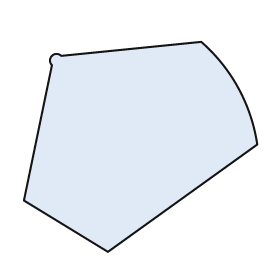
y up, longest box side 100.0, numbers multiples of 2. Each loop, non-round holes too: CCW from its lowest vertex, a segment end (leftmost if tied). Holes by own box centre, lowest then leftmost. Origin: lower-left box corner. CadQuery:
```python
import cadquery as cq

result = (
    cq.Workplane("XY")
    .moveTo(36.0, 0.0)
    .lineTo(100.0, 46.0)
    .threePointArc((92.0, 70.0), (76.0, 90.0))
    .lineTo(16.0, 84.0)
    .threePointArc((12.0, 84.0), (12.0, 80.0))
    .lineTo(0.0, 22.0)
    .close()
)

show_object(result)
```